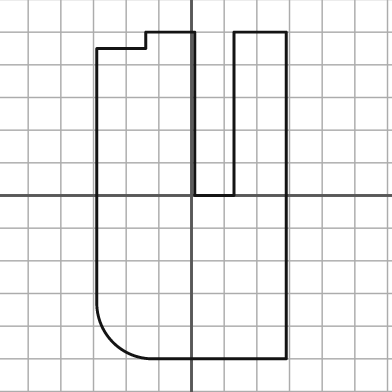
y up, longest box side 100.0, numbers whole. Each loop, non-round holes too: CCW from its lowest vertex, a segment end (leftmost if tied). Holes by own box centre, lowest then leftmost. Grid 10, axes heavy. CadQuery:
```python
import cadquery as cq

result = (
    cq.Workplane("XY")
    .moveTo(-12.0, -50.0)
    .lineTo(29.0, -50.0)
    .lineTo(29.0, 50.0)
    .lineTo(13.0, 50.0)
    .lineTo(13.0, 0.0)
    .lineTo(1.0, 0.0)
    .lineTo(1.0, 50.0)
    .lineTo(-14.0, 50.0)
    .lineTo(-14.0, 45.0)
    .lineTo(-29.0, 45.0)
    .lineTo(-29.0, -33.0)
    .threePointArc((-24.0, -45.0), (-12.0, -50.0))
    .close()
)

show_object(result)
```